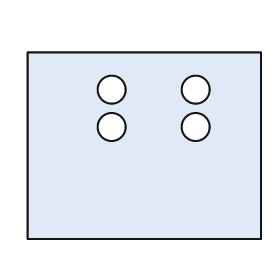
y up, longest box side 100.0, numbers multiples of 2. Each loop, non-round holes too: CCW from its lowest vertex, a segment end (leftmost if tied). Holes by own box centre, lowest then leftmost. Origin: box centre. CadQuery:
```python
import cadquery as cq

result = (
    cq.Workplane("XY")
    .moveTo(-50.0, -40.0)
    .lineTo(50.0, -40.0)
    .lineTo(50.0, 40.0)
    .lineTo(-50.0, 40.0)
    .close()
    .moveTo(-14.0, 8.0)
    .circle(6.0)
    .moveTo(22.0, 8.0)
    .circle(6.0)
    .moveTo(-14.0, 24.0)
    .circle(6.0)
    .moveTo(22.0, 24.0)
    .circle(6.0)
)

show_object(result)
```